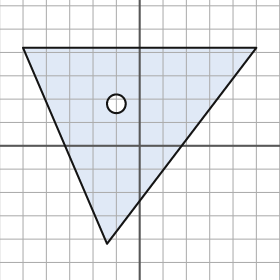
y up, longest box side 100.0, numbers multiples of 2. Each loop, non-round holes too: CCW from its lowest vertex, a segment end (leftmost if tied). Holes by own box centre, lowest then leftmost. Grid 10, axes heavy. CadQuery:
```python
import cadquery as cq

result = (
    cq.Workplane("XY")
    .moveTo(-14.0, -42.0)
    .lineTo(50.0, 42.0)
    .lineTo(-50.0, 42.0)
    .close()
    .moveTo(-10.0, 18.0)
    .circle(4.0)
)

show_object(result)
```